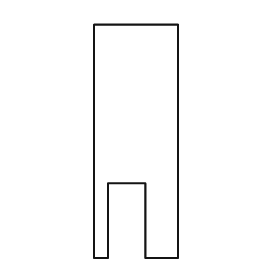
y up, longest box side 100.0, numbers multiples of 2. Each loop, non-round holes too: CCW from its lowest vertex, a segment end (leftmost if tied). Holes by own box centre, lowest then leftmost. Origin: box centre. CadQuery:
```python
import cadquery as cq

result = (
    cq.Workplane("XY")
    .moveTo(-18.0, -50.0)
    .lineTo(-12.0, -50.0)
    .lineTo(-12.0, -18.0)
    .lineTo(4.0, -18.0)
    .lineTo(4.0, -50.0)
    .lineTo(18.0, -50.0)
    .lineTo(18.0, 50.0)
    .lineTo(-18.0, 50.0)
    .close()
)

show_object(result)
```